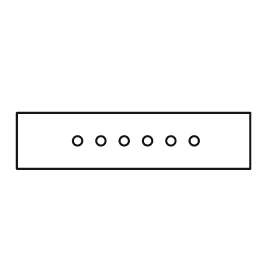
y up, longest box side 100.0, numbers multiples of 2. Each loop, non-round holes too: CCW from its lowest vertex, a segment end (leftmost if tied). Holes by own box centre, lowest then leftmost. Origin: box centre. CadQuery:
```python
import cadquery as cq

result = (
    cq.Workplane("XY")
    .moveTo(-50.0, -12.0)
    .lineTo(50.0, -12.0)
    .lineTo(50.0, 12.0)
    .lineTo(-50.0, 12.0)
    .close()
    .moveTo(-24.0, 0.0)
    .circle(2.0)
    .moveTo(-14.0, 0.0)
    .circle(2.0)
    .moveTo(-4.0, 0.0)
    .circle(2.0)
    .moveTo(6.0, 0.0)
    .circle(2.0)
    .moveTo(16.0, 0.0)
    .circle(2.0)
    .moveTo(26.0, 0.0)
    .circle(2.0)
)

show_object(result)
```